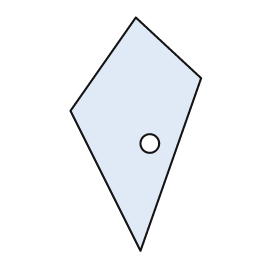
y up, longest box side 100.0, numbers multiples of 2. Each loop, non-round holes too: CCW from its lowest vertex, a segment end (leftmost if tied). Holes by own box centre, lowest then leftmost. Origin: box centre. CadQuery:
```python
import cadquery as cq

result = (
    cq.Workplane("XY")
    .moveTo(2.0, -50.0)
    .lineTo(28.0, 24.0)
    .lineTo(0.0, 50.0)
    .lineTo(-28.0, 10.0)
    .close()
    .moveTo(6.0, -4.0)
    .circle(4.0)
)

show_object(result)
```